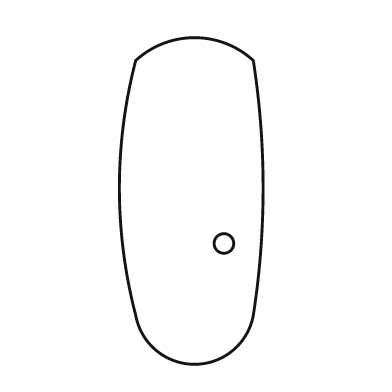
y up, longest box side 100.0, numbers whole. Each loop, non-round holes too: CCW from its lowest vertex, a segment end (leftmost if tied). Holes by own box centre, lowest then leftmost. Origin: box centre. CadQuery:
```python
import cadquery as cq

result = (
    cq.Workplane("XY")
    .moveTo(-17.0, -35.0)
    .threePointArc((1.0, -50.0), (19.0, -35.0))
    .threePointArc((22.0, 4.0), (19.0, 43.0))
    .threePointArc((1.0, 50.0), (-17.0, 43.0))
    .threePointArc((-22.0, 4.0), (-17.0, -35.0))
    .close()
    .moveTo(10.0, -13.0)
    .circle(3.0)
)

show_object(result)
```